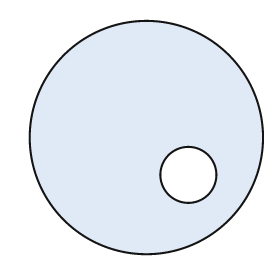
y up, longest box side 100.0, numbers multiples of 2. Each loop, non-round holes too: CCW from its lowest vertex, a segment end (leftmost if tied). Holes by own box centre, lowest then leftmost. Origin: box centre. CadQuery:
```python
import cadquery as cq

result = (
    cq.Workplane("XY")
    .moveTo(0.0, 0.0)
    .circle(50.0)
    .moveTo(18.0, -16.0)
    .circle(12.0)
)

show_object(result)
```